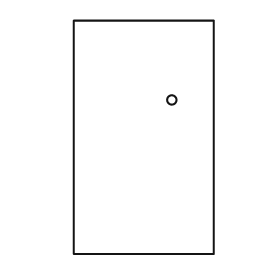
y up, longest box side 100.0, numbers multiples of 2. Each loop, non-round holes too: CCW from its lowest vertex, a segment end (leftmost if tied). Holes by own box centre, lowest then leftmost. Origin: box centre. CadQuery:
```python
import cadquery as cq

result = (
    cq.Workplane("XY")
    .moveTo(-30.0, -50.0)
    .lineTo(30.0, -50.0)
    .lineTo(30.0, 50.0)
    .lineTo(-30.0, 50.0)
    .close()
    .moveTo(12.0, 16.0)
    .circle(2.0)
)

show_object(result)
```